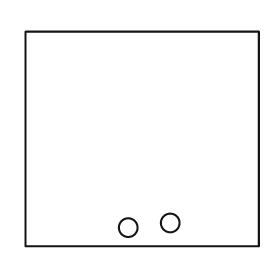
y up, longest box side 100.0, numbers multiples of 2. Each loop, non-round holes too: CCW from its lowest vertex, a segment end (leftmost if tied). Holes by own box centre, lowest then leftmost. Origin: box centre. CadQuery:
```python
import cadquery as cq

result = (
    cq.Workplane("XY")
    .moveTo(-50.0, -46.0)
    .lineTo(50.0, -46.0)
    .lineTo(50.0, 46.0)
    .lineTo(-50.0, 46.0)
    .close()
    .moveTo(-6.0, -38.0)
    .circle(4.0)
    .moveTo(12.0, -36.0)
    .circle(4.0)
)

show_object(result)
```